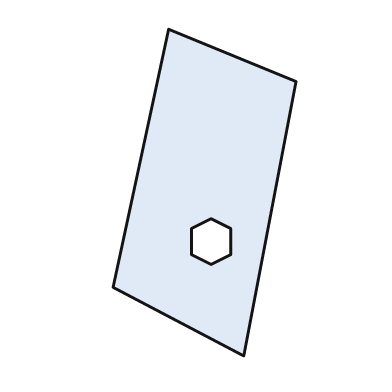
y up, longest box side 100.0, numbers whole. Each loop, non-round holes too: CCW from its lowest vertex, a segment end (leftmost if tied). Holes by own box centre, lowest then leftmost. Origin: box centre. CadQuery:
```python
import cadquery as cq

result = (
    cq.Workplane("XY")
    .moveTo(12.0, -50.0)
    .lineTo(28.0, 34.0)
    .lineTo(-11.0, 50.0)
    .lineTo(-28.0, -29.0)
    .close()
    .moveTo(2.0, -22.0)
    .lineTo(8.0, -19.0)
    .lineTo(8.0, -11.0)
    .lineTo(2.0, -8.0)
    .lineTo(-4.0, -11.0)
    .lineTo(-4.0, -19.0)
    .close()
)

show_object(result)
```